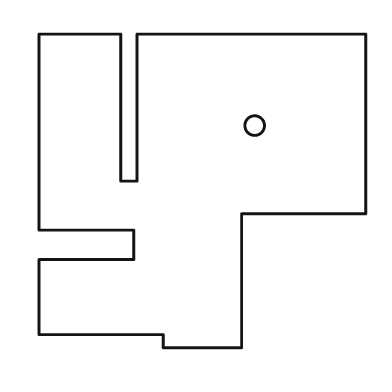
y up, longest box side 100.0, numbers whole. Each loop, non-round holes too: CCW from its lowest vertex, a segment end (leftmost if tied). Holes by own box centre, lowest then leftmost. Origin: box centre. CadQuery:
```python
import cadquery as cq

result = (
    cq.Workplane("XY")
    .moveTo(-12.0, -48.0)
    .lineTo(12.0, -48.0)
    .lineTo(12.0, -7.0)
    .lineTo(50.0, -7.0)
    .lineTo(50.0, 48.0)
    .lineTo(-20.0, 48.0)
    .lineTo(-20.0, 3.0)
    .lineTo(-25.0, 3.0)
    .lineTo(-25.0, 48.0)
    .lineTo(-50.0, 48.0)
    .lineTo(-50.0, -12.0)
    .lineTo(-21.0, -12.0)
    .lineTo(-21.0, -21.0)
    .lineTo(-50.0, -21.0)
    .lineTo(-50.0, -44.0)
    .lineTo(-12.0, -44.0)
    .close()
    .moveTo(16.0, 20.0)
    .circle(3.0)
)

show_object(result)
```